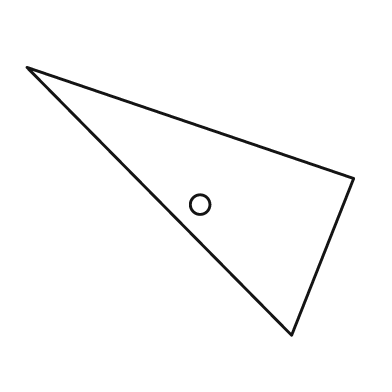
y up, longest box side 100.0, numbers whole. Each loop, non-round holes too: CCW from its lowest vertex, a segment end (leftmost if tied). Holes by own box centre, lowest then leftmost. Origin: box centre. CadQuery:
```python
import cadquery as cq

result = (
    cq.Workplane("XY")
    .moveTo(31.0, -41.0)
    .lineTo(50.0, 7.0)
    .lineTo(-50.0, 41.0)
    .close()
    .moveTo(3.0, -1.0)
    .circle(3.0)
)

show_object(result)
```